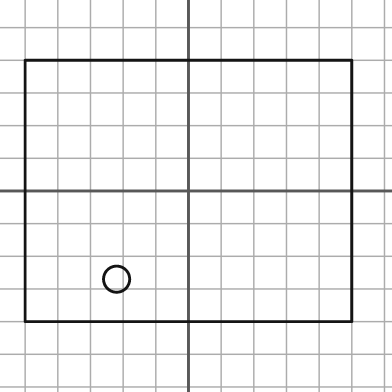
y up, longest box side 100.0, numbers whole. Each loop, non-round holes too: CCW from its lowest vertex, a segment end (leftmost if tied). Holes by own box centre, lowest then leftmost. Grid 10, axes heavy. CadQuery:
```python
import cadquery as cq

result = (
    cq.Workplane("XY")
    .moveTo(-50.0, -40.0)
    .lineTo(50.0, -40.0)
    .lineTo(50.0, 40.0)
    .lineTo(-50.0, 40.0)
    .close()
    .moveTo(-22.0, -27.0)
    .circle(4.0)
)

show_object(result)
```